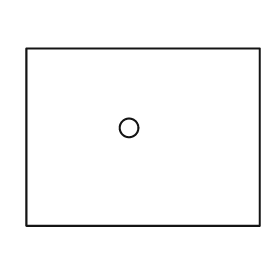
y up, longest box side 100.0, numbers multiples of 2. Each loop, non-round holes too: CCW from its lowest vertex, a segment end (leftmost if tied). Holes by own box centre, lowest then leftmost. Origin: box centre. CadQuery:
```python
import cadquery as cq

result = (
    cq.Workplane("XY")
    .moveTo(-50.0, -38.0)
    .lineTo(50.0, -38.0)
    .lineTo(50.0, 38.0)
    .lineTo(-50.0, 38.0)
    .close()
    .moveTo(-6.0, 4.0)
    .circle(4.0)
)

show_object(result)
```